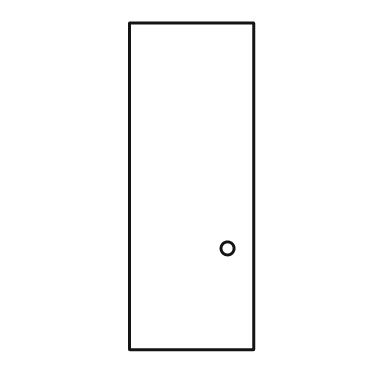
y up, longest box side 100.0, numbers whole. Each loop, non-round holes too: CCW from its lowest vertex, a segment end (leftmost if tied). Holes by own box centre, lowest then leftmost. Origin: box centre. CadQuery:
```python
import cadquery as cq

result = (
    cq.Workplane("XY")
    .moveTo(-19.0, -50.0)
    .lineTo(19.0, -50.0)
    .lineTo(19.0, 50.0)
    .lineTo(-19.0, 50.0)
    .close()
    .moveTo(11.0, -19.0)
    .circle(2.0)
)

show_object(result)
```